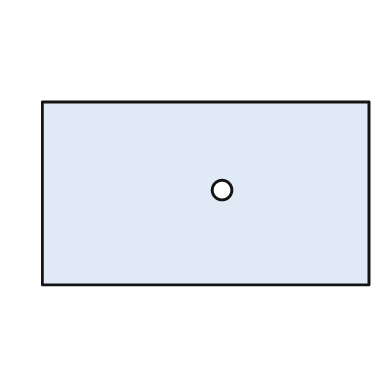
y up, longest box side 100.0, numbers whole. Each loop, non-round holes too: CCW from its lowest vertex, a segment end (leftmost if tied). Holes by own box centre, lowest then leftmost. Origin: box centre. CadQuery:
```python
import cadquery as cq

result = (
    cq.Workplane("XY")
    .moveTo(-50.0, -28.0)
    .lineTo(50.0, -28.0)
    .lineTo(50.0, 28.0)
    .lineTo(-50.0, 28.0)
    .close()
    .moveTo(5.0, 1.0)
    .circle(3.0)
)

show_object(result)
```